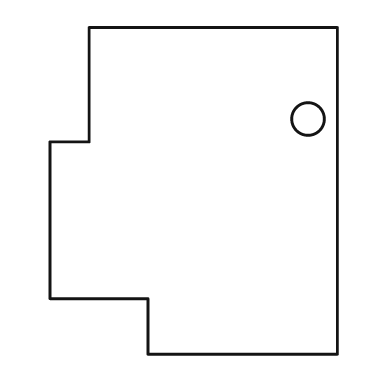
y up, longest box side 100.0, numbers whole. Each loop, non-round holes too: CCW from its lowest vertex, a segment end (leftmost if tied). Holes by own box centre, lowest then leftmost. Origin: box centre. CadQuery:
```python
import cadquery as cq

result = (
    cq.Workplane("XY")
    .moveTo(-14.0, -50.0)
    .lineTo(44.0, -50.0)
    .lineTo(44.0, 50.0)
    .lineTo(-32.0, 50.0)
    .lineTo(-32.0, 15.0)
    .lineTo(-44.0, 15.0)
    .lineTo(-44.0, -33.0)
    .lineTo(-14.0, -33.0)
    .close()
    .moveTo(35.0, 22.0)
    .circle(5.0)
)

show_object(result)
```